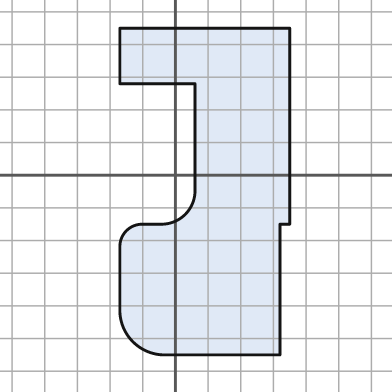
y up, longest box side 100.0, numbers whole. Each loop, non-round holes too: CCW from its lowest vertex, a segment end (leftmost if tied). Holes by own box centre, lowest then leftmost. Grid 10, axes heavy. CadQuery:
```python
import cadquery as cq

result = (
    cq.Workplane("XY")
    .moveTo(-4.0, -55.0)
    .lineTo(32.0, -55.0)
    .lineTo(32.0, -15.0)
    .lineTo(35.0, -15.0)
    .lineTo(35.0, 45.0)
    .lineTo(-17.0, 45.0)
    .lineTo(-17.0, 28.0)
    .lineTo(6.0, 28.0)
    .lineTo(6.0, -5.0)
    .threePointArc((3.0, -12.0), (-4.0, -15.0))
    .lineTo(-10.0, -15.0)
    .threePointArc((-15.0, -17.0), (-17.0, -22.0))
    .lineTo(-17.0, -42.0)
    .threePointArc((-13.0, -51.0), (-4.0, -55.0))
    .close()
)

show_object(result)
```